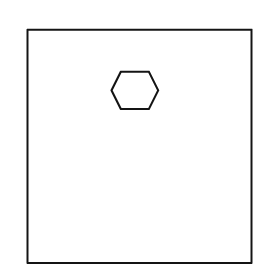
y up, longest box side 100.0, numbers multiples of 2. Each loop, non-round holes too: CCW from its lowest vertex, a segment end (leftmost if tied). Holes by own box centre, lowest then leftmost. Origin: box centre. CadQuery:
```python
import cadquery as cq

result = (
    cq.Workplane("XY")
    .moveTo(-48.0, -50.0)
    .lineTo(48.0, -50.0)
    .lineTo(48.0, 50.0)
    .lineTo(-48.0, 50.0)
    .close()
    .moveTo(-8.0, 16.0)
    .lineTo(4.0, 16.0)
    .lineTo(8.0, 24.0)
    .lineTo(4.0, 32.0)
    .lineTo(-8.0, 32.0)
    .lineTo(-12.0, 24.0)
    .close()
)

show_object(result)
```